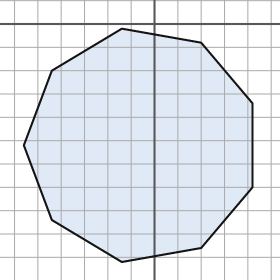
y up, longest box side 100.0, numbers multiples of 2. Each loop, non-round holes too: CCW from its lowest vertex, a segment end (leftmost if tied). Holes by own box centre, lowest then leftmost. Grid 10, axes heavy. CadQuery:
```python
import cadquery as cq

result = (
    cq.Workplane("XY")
    .moveTo(-14.0, -102.0)
    .lineTo(20.0, -96.0)
    .lineTo(42.0, -70.0)
    .lineTo(42.0, -34.0)
    .lineTo(20.0, -8.0)
    .lineTo(-14.0, -2.0)
    .lineTo(-44.0, -20.0)
    .lineTo(-56.0, -52.0)
    .lineTo(-44.0, -84.0)
    .close()
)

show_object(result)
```